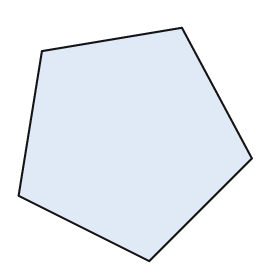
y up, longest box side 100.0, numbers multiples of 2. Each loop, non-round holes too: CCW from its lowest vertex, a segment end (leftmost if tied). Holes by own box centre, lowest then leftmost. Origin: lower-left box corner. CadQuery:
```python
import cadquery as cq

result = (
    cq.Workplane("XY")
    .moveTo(56.0, 0.0)
    .lineTo(100.0, 44.0)
    .lineTo(70.0, 100.0)
    .lineTo(10.0, 90.0)
    .lineTo(0.0, 28.0)
    .close()
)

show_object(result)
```